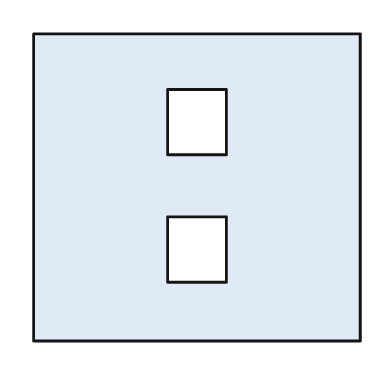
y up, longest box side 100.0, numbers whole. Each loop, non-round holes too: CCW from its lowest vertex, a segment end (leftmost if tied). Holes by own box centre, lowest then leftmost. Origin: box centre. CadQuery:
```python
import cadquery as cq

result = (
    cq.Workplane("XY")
    .moveTo(-50.0, -47.0)
    .lineTo(50.0, -47.0)
    .lineTo(50.0, 47.0)
    .lineTo(-50.0, 47.0)
    .close()
    .moveTo(-9.0, -29.0)
    .lineTo(9.0, -29.0)
    .lineTo(9.0, -9.0)
    .lineTo(-9.0, -9.0)
    .close()
    .moveTo(-9.0, 10.0)
    .lineTo(9.0, 10.0)
    .lineTo(9.0, 30.0)
    .lineTo(-9.0, 30.0)
    .close()
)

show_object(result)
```